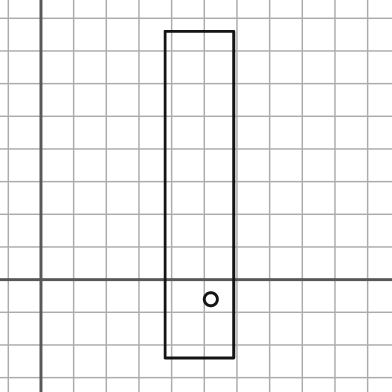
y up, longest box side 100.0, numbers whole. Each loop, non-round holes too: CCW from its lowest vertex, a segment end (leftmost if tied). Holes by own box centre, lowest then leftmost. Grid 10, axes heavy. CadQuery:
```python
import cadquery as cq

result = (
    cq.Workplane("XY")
    .moveTo(38.0, -24.0)
    .lineTo(59.0, -24.0)
    .lineTo(59.0, 76.0)
    .lineTo(38.0, 76.0)
    .close()
    .moveTo(52.0, -6.0)
    .circle(2.0)
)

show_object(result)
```